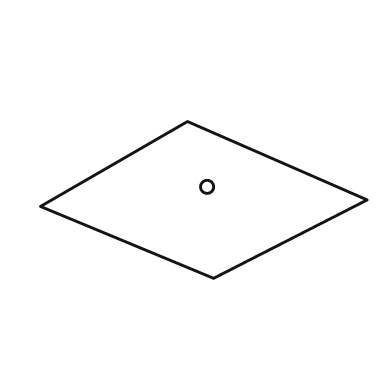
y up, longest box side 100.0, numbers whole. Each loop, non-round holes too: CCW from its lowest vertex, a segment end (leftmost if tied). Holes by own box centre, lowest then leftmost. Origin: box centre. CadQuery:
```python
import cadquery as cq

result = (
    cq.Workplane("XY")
    .moveTo(3.0, -24.0)
    .lineTo(50.0, 0.0)
    .lineTo(-5.0, 24.0)
    .lineTo(-50.0, -2.0)
    .close()
    .moveTo(1.0, 4.0)
    .circle(2.0)
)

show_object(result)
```